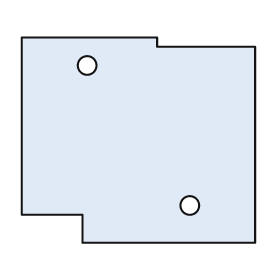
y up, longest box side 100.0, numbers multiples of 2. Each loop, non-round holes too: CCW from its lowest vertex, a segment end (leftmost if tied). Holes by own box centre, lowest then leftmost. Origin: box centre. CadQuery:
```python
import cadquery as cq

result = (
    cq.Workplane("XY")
    .moveTo(-24.0, -44.0)
    .lineTo(50.0, -44.0)
    .lineTo(50.0, 40.0)
    .lineTo(8.0, 40.0)
    .lineTo(8.0, 44.0)
    .lineTo(-50.0, 44.0)
    .lineTo(-50.0, -32.0)
    .lineTo(-24.0, -32.0)
    .close()
    .moveTo(22.0, -28.0)
    .circle(4.0)
    .moveTo(-22.0, 32.0)
    .circle(4.0)
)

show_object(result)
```